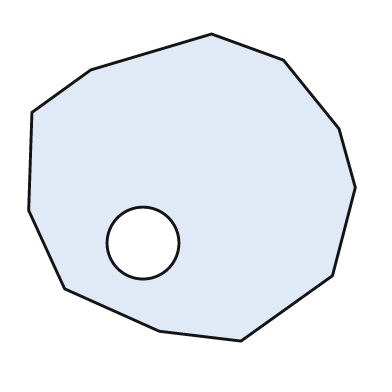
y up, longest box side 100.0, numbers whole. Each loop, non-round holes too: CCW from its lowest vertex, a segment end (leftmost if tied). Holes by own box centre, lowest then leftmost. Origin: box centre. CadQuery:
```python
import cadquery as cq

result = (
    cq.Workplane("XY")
    .moveTo(15.0, -47.0)
    .lineTo(43.0, -27.0)
    .lineTo(50.0, 0.0)
    .lineTo(45.0, 18.0)
    .lineTo(28.0, 39.0)
    .lineTo(6.0, 47.0)
    .lineTo(-31.0, 36.0)
    .lineTo(-49.0, 23.0)
    .lineTo(-50.0, -7.0)
    .lineTo(-39.0, -31.0)
    .lineTo(-10.0, -44.0)
    .close()
    .moveTo(-15.0, -17.0)
    .circle(11.0)
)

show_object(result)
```